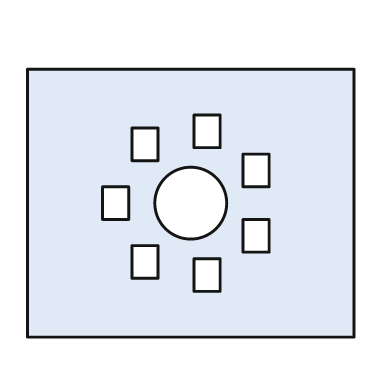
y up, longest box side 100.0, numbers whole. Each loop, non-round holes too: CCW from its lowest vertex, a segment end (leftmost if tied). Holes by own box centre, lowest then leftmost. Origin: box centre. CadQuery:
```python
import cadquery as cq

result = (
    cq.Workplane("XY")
    .moveTo(-50.0, -41.0)
    .lineTo(50.0, -41.0)
    .lineTo(50.0, 41.0)
    .lineTo(-50.0, 41.0)
    .close()
    .moveTo(1.0, -27.0)
    .lineTo(9.0, -27.0)
    .lineTo(9.0, -17.0)
    .lineTo(1.0, -17.0)
    .close()
    .moveTo(-18.0, -23.0)
    .lineTo(-10.0, -23.0)
    .lineTo(-10.0, -13.0)
    .lineTo(-18.0, -13.0)
    .close()
    .moveTo(16.0, -15.0)
    .lineTo(24.0, -15.0)
    .lineTo(24.0, -5.0)
    .lineTo(16.0, -5.0)
    .close()
    .moveTo(-27.0, -5.0)
    .lineTo(-19.0, -5.0)
    .lineTo(-19.0, 5.0)
    .lineTo(-27.0, 5.0)
    .close()
    .moveTo(0.0, 0.0)
    .circle(11.0)
    .moveTo(16.0, 5.0)
    .lineTo(24.0, 5.0)
    .lineTo(24.0, 15.0)
    .lineTo(16.0, 15.0)
    .close()
    .moveTo(-18.0, 13.0)
    .lineTo(-10.0, 13.0)
    .lineTo(-10.0, 23.0)
    .lineTo(-18.0, 23.0)
    .close()
    .moveTo(1.0, 17.0)
    .lineTo(9.0, 17.0)
    .lineTo(9.0, 27.0)
    .lineTo(1.0, 27.0)
    .close()
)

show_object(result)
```